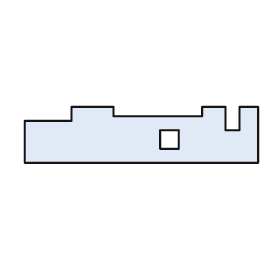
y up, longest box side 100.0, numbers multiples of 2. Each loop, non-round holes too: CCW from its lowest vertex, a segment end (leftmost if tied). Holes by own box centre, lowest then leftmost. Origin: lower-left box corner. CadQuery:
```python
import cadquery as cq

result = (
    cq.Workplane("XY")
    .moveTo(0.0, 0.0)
    .lineTo(100.0, 0.0)
    .lineTo(100.0, 24.0)
    .lineTo(92.0, 24.0)
    .lineTo(92.0, 14.0)
    .lineTo(86.0, 14.0)
    .lineTo(86.0, 24.0)
    .lineTo(76.0, 24.0)
    .lineTo(76.0, 20.0)
    .lineTo(38.0, 20.0)
    .lineTo(38.0, 24.0)
    .lineTo(20.0, 24.0)
    .lineTo(20.0, 18.0)
    .lineTo(0.0, 18.0)
    .close()
    .moveTo(58.0, 6.0)
    .lineTo(66.0, 6.0)
    .lineTo(66.0, 14.0)
    .lineTo(58.0, 14.0)
    .close()
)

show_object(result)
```